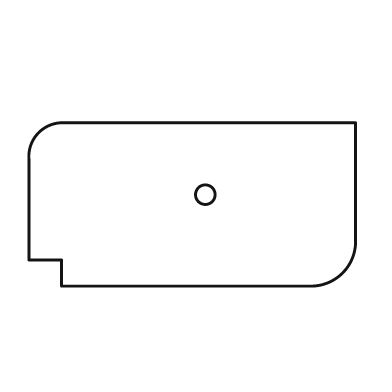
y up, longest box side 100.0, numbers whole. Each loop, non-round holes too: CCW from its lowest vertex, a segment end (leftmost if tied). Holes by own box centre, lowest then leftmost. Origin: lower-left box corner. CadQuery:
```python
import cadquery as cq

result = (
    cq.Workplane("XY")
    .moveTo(10.0, 0.0)
    .lineTo(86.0, 0.0)
    .threePointArc((96.0, 4.0), (100.0, 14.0))
    .lineTo(100.0, 50.0)
    .lineTo(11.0, 50.0)
    .threePointArc((3.0, 47.0), (0.0, 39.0))
    .lineTo(0.0, 8.0)
    .lineTo(10.0, 8.0)
    .close()
    .moveTo(54.0, 28.0)
    .circle(3.0)
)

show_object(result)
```